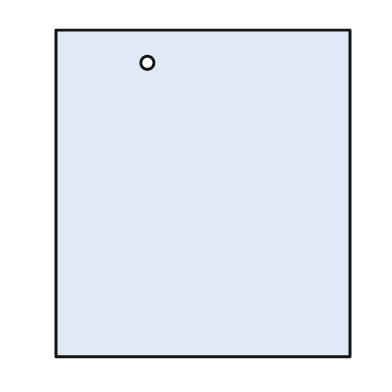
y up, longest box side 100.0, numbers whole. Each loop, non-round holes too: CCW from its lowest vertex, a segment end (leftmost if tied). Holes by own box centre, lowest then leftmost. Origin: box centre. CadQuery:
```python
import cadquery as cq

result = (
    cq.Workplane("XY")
    .moveTo(-45.0, -50.0)
    .lineTo(45.0, -50.0)
    .lineTo(45.0, 50.0)
    .lineTo(-45.0, 50.0)
    .close()
    .moveTo(-17.0, 40.0)
    .circle(2.0)
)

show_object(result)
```